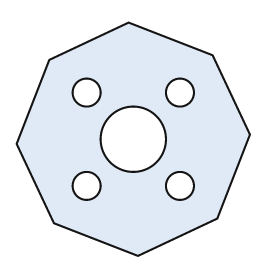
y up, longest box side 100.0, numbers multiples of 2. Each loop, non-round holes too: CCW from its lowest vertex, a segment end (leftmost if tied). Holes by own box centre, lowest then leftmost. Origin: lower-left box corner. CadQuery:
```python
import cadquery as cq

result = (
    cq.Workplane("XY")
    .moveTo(52.0, 0.0)
    .lineTo(86.0, 16.0)
    .lineTo(100.0, 52.0)
    .lineTo(84.0, 86.0)
    .lineTo(48.0, 100.0)
    .lineTo(14.0, 84.0)
    .lineTo(0.0, 48.0)
    .lineTo(16.0, 14.0)
    .close()
    .moveTo(30.0, 30.0)
    .circle(6.0)
    .moveTo(70.0, 30.0)
    .circle(6.0)
    .moveTo(50.0, 50.0)
    .circle(14.0)
    .moveTo(30.0, 70.0)
    .circle(6.0)
    .moveTo(70.0, 70.0)
    .circle(6.0)
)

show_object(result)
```